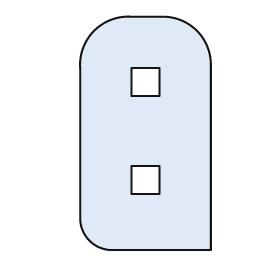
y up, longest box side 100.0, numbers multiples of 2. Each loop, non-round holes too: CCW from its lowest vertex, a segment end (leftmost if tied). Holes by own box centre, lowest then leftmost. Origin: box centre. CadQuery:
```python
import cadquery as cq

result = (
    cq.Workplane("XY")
    .moveTo(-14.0, -50.0)
    .lineTo(28.0, -50.0)
    .lineTo(28.0, 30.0)
    .threePointArc((22.0, 44.0), (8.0, 50.0))
    .lineTo(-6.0, 50.0)
    .threePointArc((-22.0, 44.0), (-28.0, 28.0))
    .lineTo(-28.0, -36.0)
    .threePointArc((-24.0, -46.0), (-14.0, -50.0))
    .close()
    .moveTo(-6.0, -26.0)
    .lineTo(6.0, -26.0)
    .lineTo(6.0, -14.0)
    .lineTo(-6.0, -14.0)
    .close()
    .moveTo(-6.0, 16.0)
    .lineTo(6.0, 16.0)
    .lineTo(6.0, 28.0)
    .lineTo(-6.0, 28.0)
    .close()
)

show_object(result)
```